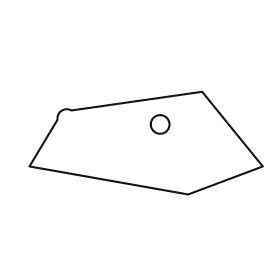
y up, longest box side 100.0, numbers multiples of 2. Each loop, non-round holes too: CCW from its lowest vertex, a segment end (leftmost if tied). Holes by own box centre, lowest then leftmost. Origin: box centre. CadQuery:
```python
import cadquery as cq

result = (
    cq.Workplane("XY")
    .moveTo(18.0, -22.0)
    .lineTo(50.0, -10.0)
    .lineTo(24.0, 22.0)
    .lineTo(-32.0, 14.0)
    .threePointArc((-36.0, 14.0), (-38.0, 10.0))
    .lineTo(-50.0, -10.0)
    .close()
    .moveTo(6.0, 8.0)
    .circle(4.0)
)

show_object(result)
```